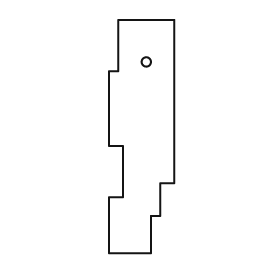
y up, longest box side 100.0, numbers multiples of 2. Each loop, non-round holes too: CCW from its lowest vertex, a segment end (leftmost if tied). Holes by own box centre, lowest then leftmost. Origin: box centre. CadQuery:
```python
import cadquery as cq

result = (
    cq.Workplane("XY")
    .moveTo(-14.0, -50.0)
    .lineTo(4.0, -50.0)
    .lineTo(4.0, -34.0)
    .lineTo(8.0, -34.0)
    .lineTo(8.0, -20.0)
    .lineTo(14.0, -20.0)
    .lineTo(14.0, 50.0)
    .lineTo(-10.0, 50.0)
    .lineTo(-10.0, 28.0)
    .lineTo(-14.0, 28.0)
    .lineTo(-14.0, -4.0)
    .lineTo(-8.0, -4.0)
    .lineTo(-8.0, -26.0)
    .lineTo(-14.0, -26.0)
    .close()
    .moveTo(2.0, 32.0)
    .circle(2.0)
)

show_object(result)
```